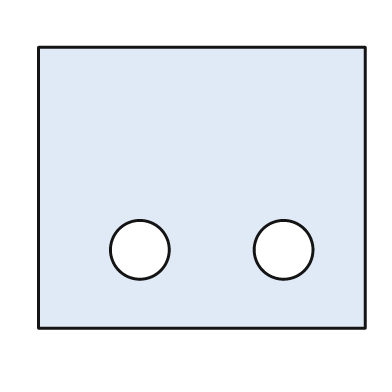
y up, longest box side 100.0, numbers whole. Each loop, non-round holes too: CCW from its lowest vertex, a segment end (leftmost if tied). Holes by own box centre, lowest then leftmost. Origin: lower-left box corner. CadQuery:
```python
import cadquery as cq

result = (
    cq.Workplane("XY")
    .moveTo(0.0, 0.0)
    .lineTo(100.0, 0.0)
    .lineTo(100.0, 86.0)
    .lineTo(0.0, 86.0)
    .close()
    .moveTo(31.0, 24.0)
    .circle(9.0)
    .moveTo(75.0, 24.0)
    .circle(9.0)
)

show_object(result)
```